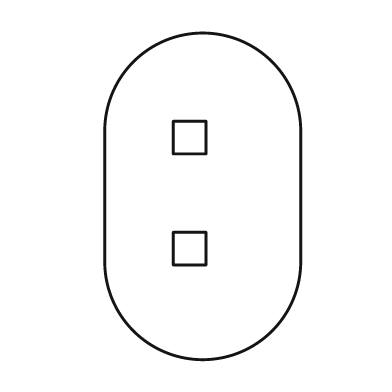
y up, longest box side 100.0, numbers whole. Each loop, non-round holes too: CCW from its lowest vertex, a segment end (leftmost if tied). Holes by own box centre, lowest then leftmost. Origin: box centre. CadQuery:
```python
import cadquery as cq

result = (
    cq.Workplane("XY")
    .moveTo(-30.0, -20.0)
    .threePointArc((0.0, -50.0), (30.0, -20.0))
    .lineTo(30.0, 20.0)
    .threePointArc((0.0, 50.0), (-30.0, 20.0))
    .close()
    .moveTo(-9.0, -21.0)
    .lineTo(1.0, -21.0)
    .lineTo(1.0, -11.0)
    .lineTo(-9.0, -11.0)
    .close()
    .moveTo(-9.0, 13.0)
    .lineTo(1.0, 13.0)
    .lineTo(1.0, 23.0)
    .lineTo(-9.0, 23.0)
    .close()
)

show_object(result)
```